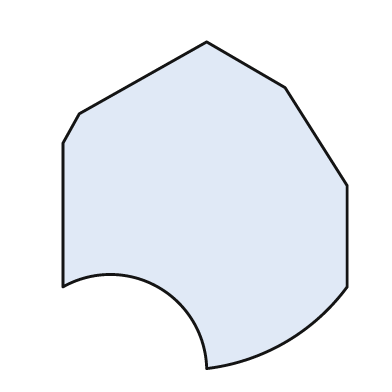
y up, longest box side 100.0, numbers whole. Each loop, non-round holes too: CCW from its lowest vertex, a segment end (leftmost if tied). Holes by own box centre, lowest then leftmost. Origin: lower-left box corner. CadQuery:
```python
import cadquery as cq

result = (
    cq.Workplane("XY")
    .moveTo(44.0, 0.0)
    .threePointArc((68.0, 8.0), (87.0, 25.0))
    .lineTo(87.0, 56.0)
    .lineTo(68.0, 86.0)
    .lineTo(44.0, 100.0)
    .lineTo(5.0, 78.0)
    .lineTo(0.0, 69.0)
    .lineTo(0.0, 25.0)
    .threePointArc((29.0, 25.0), (44.0, 0.0))
    .close()
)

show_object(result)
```